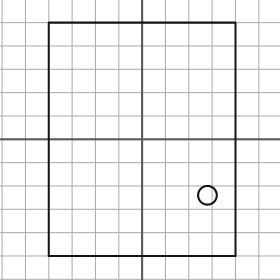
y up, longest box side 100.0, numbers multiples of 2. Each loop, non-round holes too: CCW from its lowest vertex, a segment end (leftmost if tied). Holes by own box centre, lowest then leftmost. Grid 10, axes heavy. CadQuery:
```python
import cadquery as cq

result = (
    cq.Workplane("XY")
    .moveTo(-40.0, -50.0)
    .lineTo(40.0, -50.0)
    .lineTo(40.0, 50.0)
    .lineTo(-40.0, 50.0)
    .close()
    .moveTo(28.0, -24.0)
    .circle(4.0)
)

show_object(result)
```